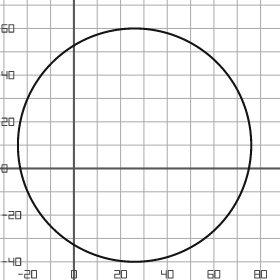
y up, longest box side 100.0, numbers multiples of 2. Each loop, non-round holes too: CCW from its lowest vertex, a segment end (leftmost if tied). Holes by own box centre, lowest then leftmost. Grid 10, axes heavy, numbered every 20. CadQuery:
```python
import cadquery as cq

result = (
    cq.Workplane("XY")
    .moveTo(26.0, 10.0)
    .circle(50.0)
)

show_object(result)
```